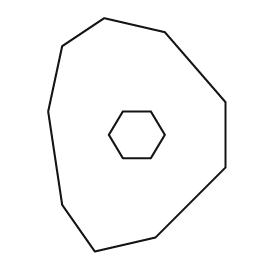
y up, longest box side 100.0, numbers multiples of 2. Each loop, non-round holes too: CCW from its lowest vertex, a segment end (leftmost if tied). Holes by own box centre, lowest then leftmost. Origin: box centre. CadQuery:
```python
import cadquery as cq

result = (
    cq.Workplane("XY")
    .moveTo(-18.0, -50.0)
    .lineTo(8.0, -44.0)
    .lineTo(38.0, -14.0)
    .lineTo(38.0, 14.0)
    .lineTo(12.0, 44.0)
    .lineTo(-14.0, 50.0)
    .lineTo(-32.0, 38.0)
    .lineTo(-38.0, 10.0)
    .lineTo(-32.0, -30.0)
    .close()
    .moveTo(-6.0, -10.0)
    .lineTo(6.0, -10.0)
    .lineTo(12.0, 0.0)
    .lineTo(6.0, 10.0)
    .lineTo(-6.0, 10.0)
    .lineTo(-12.0, 0.0)
    .close()
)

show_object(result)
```